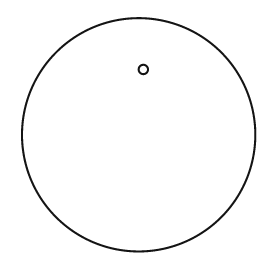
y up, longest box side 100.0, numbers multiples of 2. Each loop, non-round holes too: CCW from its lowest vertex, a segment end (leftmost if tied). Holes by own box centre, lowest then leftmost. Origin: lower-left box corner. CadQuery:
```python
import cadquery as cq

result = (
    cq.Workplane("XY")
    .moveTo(50.0, 50.0)
    .circle(50.0)
    .moveTo(52.0, 78.0)
    .circle(2.0)
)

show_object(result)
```